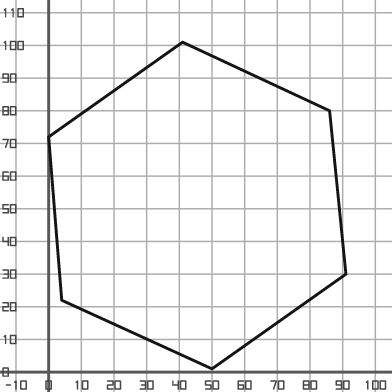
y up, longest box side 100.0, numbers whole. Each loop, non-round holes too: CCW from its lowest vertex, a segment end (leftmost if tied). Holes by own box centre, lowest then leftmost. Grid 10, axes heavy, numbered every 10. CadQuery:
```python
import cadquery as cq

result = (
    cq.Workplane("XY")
    .moveTo(50.0, 1.0)
    .lineTo(91.0, 30.0)
    .lineTo(86.0, 80.0)
    .lineTo(41.0, 101.0)
    .lineTo(0.0, 72.0)
    .lineTo(4.0, 22.0)
    .close()
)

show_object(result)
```